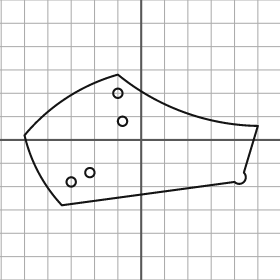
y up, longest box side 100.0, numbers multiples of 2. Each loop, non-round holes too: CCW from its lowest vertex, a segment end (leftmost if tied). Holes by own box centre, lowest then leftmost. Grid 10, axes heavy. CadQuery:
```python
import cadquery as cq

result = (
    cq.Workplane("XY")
    .moveTo(-34.0, -28.0)
    .lineTo(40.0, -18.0)
    .threePointArc((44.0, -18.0), (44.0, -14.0))
    .lineTo(50.0, 6.0)
    .threePointArc((18.0, 12.0), (-10.0, 28.0))
    .threePointArc((-32.0, 18.0), (-50.0, 2.0))
    .threePointArc((-44.0, -14.0), (-34.0, -28.0))
    .close()
    .moveTo(-30.0, -18.0)
    .circle(2.0)
    .moveTo(-22.0, -14.0)
    .circle(2.0)
    .moveTo(-8.0, 8.0)
    .circle(2.0)
    .moveTo(-10.0, 20.0)
    .circle(2.0)
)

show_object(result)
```